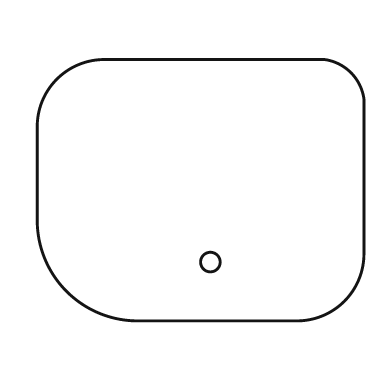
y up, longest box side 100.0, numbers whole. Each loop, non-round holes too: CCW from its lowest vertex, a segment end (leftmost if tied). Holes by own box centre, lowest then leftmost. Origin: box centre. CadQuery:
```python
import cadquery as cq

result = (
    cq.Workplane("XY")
    .moveTo(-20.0, -40.0)
    .lineTo(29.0, -40.0)
    .threePointArc((44.0, -34.0), (50.0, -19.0))
    .lineTo(50.0, 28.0)
    .threePointArc((46.0, 36.0), (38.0, 40.0))
    .lineTo(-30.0, 40.0)
    .threePointArc((-44.0, 34.0), (-50.0, 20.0))
    .lineTo(-50.0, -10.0)
    .threePointArc((-41.0, -31.0), (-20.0, -40.0))
    .close()
    .moveTo(3.0, -22.0)
    .circle(3.0)
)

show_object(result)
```